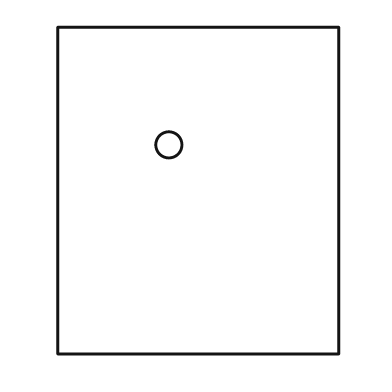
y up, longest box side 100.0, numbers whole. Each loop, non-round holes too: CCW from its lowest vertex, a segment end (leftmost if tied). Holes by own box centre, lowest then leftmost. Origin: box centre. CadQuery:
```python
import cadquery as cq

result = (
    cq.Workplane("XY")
    .moveTo(-43.0, -50.0)
    .lineTo(43.0, -50.0)
    .lineTo(43.0, 50.0)
    .lineTo(-43.0, 50.0)
    .close()
    .moveTo(-9.0, 14.0)
    .circle(4.0)
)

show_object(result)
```